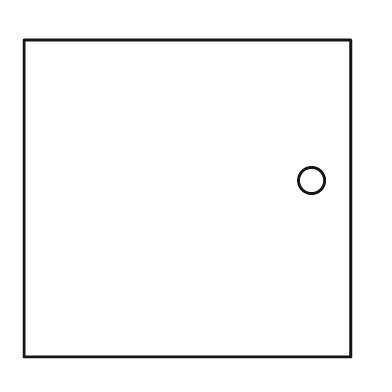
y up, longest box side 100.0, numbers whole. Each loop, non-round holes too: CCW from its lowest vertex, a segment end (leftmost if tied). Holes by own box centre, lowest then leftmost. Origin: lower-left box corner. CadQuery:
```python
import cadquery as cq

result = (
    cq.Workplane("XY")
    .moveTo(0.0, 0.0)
    .lineTo(100.0, 0.0)
    .lineTo(100.0, 97.0)
    .lineTo(0.0, 97.0)
    .close()
    .moveTo(88.0, 54.0)
    .circle(4.0)
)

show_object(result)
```